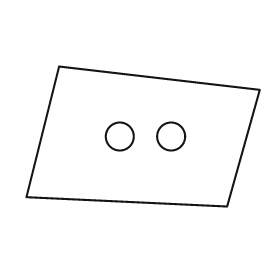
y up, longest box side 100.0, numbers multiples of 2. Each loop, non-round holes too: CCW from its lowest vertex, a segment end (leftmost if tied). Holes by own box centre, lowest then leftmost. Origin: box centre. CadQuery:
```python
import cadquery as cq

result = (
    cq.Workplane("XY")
    .moveTo(36.0, -30.0)
    .lineTo(50.0, 20.0)
    .lineTo(-36.0, 30.0)
    .lineTo(-50.0, -26.0)
    .close()
    .moveTo(-10.0, 0.0)
    .circle(6.0)
    .moveTo(12.0, 0.0)
    .circle(6.0)
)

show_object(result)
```